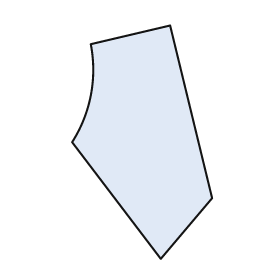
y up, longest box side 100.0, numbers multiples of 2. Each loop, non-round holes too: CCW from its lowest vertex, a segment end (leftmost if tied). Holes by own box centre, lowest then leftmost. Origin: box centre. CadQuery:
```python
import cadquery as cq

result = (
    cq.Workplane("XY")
    .moveTo(8.0, -50.0)
    .lineTo(30.0, -24.0)
    .lineTo(12.0, 50.0)
    .lineTo(-22.0, 42.0)
    .threePointArc((-22.0, 20.0), (-30.0, 0.0))
    .close()
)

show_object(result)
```